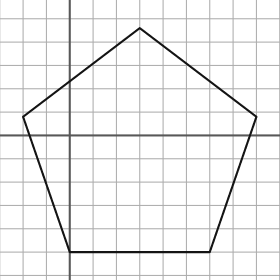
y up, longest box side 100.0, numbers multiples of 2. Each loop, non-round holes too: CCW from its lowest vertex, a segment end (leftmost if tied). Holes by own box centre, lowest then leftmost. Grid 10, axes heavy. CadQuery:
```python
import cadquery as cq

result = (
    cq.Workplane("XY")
    .moveTo(0.0, -50.0)
    .lineTo(60.0, -50.0)
    .lineTo(80.0, 8.0)
    .lineTo(30.0, 46.0)
    .lineTo(-20.0, 8.0)
    .close()
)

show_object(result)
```